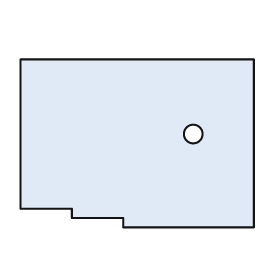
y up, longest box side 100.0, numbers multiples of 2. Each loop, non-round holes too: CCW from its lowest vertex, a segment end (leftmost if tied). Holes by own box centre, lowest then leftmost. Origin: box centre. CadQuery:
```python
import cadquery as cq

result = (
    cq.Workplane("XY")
    .moveTo(-6.0, -36.0)
    .lineTo(50.0, -36.0)
    .lineTo(50.0, 36.0)
    .lineTo(-50.0, 36.0)
    .lineTo(-50.0, -28.0)
    .lineTo(-28.0, -28.0)
    .lineTo(-28.0, -32.0)
    .lineTo(-6.0, -32.0)
    .close()
    .moveTo(24.0, 4.0)
    .circle(4.0)
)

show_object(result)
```